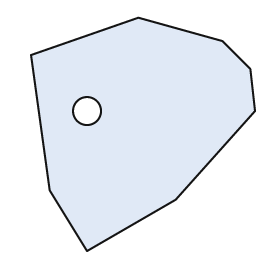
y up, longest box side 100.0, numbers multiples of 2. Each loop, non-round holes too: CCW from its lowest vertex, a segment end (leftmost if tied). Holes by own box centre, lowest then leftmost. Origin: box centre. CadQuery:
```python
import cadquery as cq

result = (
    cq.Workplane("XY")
    .moveTo(-24.0, -50.0)
    .lineTo(14.0, -28.0)
    .lineTo(48.0, 10.0)
    .lineTo(46.0, 28.0)
    .lineTo(34.0, 40.0)
    .lineTo(-2.0, 50.0)
    .lineTo(-48.0, 34.0)
    .lineTo(-40.0, -24.0)
    .close()
    .moveTo(-24.0, 10.0)
    .circle(6.0)
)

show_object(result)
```